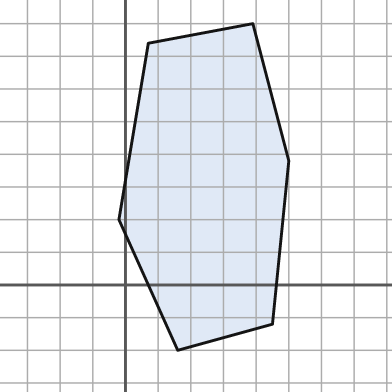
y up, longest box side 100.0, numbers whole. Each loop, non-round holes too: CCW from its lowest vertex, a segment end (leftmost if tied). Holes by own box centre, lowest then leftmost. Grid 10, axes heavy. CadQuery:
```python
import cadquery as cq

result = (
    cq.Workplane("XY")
    .moveTo(16.0, -20.0)
    .lineTo(45.0, -12.0)
    .lineTo(50.0, 38.0)
    .lineTo(39.0, 80.0)
    .lineTo(7.0, 74.0)
    .lineTo(-2.0, 20.0)
    .close()
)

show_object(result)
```